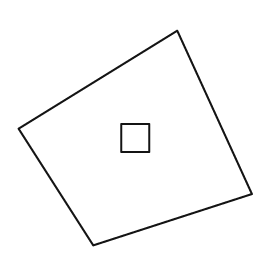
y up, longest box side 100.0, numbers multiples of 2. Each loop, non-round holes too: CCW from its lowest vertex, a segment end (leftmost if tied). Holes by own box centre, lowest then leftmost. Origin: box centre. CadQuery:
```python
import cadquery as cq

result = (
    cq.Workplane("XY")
    .moveTo(-18.0, -46.0)
    .lineTo(50.0, -24.0)
    .lineTo(18.0, 46.0)
    .lineTo(-50.0, 4.0)
    .close()
    .moveTo(-6.0, -6.0)
    .lineTo(6.0, -6.0)
    .lineTo(6.0, 6.0)
    .lineTo(-6.0, 6.0)
    .close()
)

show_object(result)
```